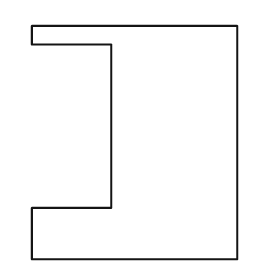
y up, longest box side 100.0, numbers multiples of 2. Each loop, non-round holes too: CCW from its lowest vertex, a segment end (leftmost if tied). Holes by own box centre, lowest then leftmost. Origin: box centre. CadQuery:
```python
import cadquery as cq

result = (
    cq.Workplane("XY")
    .moveTo(-44.0, -50.0)
    .lineTo(44.0, -50.0)
    .lineTo(44.0, 50.0)
    .lineTo(-44.0, 50.0)
    .lineTo(-44.0, 42.0)
    .lineTo(-10.0, 42.0)
    .lineTo(-10.0, -28.0)
    .lineTo(-44.0, -28.0)
    .close()
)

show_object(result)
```